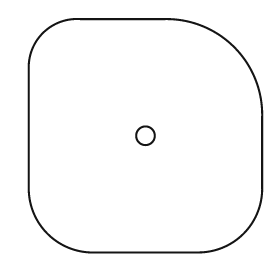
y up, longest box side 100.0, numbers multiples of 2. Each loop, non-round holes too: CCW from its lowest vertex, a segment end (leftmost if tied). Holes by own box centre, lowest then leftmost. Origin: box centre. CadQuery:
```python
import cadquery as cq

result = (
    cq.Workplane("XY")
    .moveTo(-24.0, -50.0)
    .lineTo(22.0, -50.0)
    .threePointArc((42.0, -42.0), (50.0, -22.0))
    .lineTo(50.0, 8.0)
    .threePointArc((38.0, 38.0), (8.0, 50.0))
    .lineTo(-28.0, 50.0)
    .threePointArc((-44.0, 44.0), (-50.0, 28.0))
    .lineTo(-50.0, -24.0)
    .threePointArc((-42.0, -42.0), (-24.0, -50.0))
    .close()
    .moveTo(0.0, 0.0)
    .circle(4.0)
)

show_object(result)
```